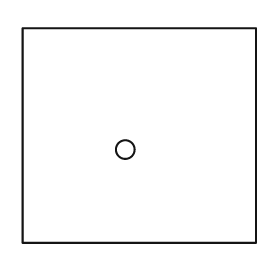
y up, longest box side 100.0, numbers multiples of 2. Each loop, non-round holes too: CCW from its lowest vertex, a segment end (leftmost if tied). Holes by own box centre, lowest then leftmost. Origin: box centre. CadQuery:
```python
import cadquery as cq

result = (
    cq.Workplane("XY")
    .moveTo(-50.0, -46.0)
    .lineTo(50.0, -46.0)
    .lineTo(50.0, 46.0)
    .lineTo(-50.0, 46.0)
    .close()
    .moveTo(-6.0, -6.0)
    .circle(4.0)
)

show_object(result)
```